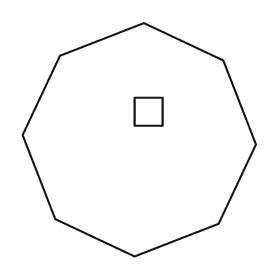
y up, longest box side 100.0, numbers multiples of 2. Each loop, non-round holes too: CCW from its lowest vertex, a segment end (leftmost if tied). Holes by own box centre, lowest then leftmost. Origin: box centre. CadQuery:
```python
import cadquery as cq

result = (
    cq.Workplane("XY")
    .moveTo(-2.0, -50.0)
    .lineTo(34.0, -36.0)
    .lineTo(50.0, -2.0)
    .lineTo(36.0, 34.0)
    .lineTo(2.0, 50.0)
    .lineTo(-34.0, 36.0)
    .lineTo(-50.0, 2.0)
    .lineTo(-36.0, -34.0)
    .close()
    .moveTo(-2.0, 6.0)
    .lineTo(10.0, 6.0)
    .lineTo(10.0, 18.0)
    .lineTo(-2.0, 18.0)
    .close()
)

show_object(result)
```